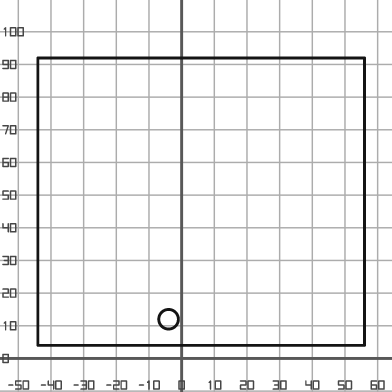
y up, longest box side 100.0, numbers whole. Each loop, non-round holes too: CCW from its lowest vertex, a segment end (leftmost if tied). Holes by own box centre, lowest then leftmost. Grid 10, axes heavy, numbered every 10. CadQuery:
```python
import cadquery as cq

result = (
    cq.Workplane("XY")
    .moveTo(-44.0, 4.0)
    .lineTo(56.0, 4.0)
    .lineTo(56.0, 92.0)
    .lineTo(-44.0, 92.0)
    .close()
    .moveTo(-4.0, 12.0)
    .circle(3.0)
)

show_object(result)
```